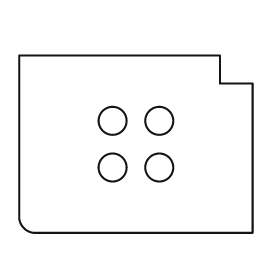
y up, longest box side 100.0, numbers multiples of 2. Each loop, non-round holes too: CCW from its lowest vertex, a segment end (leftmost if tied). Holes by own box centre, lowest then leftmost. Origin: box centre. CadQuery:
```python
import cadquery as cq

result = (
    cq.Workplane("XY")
    .moveTo(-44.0, -38.0)
    .lineTo(50.0, -38.0)
    .lineTo(50.0, 26.0)
    .lineTo(36.0, 26.0)
    .lineTo(36.0, 38.0)
    .lineTo(-50.0, 38.0)
    .lineTo(-50.0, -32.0)
    .threePointArc((-48.0, -36.0), (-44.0, -38.0))
    .close()
    .moveTo(-10.0, -10.0)
    .circle(6.0)
    .moveTo(10.0, -10.0)
    .circle(6.0)
    .moveTo(-10.0, 10.0)
    .circle(6.0)
    .moveTo(10.0, 10.0)
    .circle(6.0)
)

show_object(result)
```